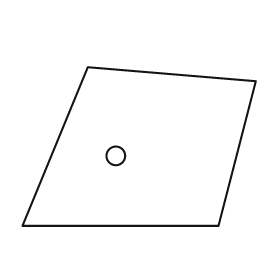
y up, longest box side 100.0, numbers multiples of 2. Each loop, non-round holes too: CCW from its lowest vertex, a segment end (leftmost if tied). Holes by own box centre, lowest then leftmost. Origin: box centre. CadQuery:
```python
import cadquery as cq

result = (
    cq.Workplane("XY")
    .moveTo(-50.0, -34.0)
    .lineTo(34.0, -34.0)
    .lineTo(50.0, 28.0)
    .lineTo(-22.0, 34.0)
    .close()
    .moveTo(-10.0, -4.0)
    .circle(4.0)
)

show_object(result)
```